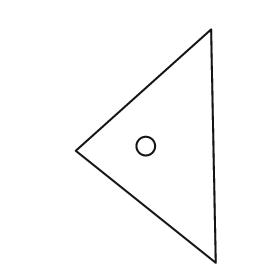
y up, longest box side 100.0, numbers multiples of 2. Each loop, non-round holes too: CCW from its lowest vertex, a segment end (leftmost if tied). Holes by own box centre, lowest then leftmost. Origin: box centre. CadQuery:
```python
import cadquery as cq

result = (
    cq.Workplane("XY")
    .moveTo(30.0, -50.0)
    .lineTo(28.0, 50.0)
    .lineTo(-30.0, -2.0)
    .close()
    .moveTo(0.0, 0.0)
    .circle(4.0)
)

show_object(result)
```